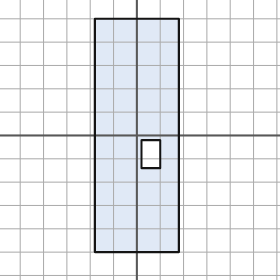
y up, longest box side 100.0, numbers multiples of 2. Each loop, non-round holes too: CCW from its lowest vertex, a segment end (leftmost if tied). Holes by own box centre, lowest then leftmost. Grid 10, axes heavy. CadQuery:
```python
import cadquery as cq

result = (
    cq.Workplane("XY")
    .moveTo(-18.0, -50.0)
    .lineTo(18.0, -50.0)
    .lineTo(18.0, 50.0)
    .lineTo(-18.0, 50.0)
    .close()
    .moveTo(2.0, -14.0)
    .lineTo(10.0, -14.0)
    .lineTo(10.0, -2.0)
    .lineTo(2.0, -2.0)
    .close()
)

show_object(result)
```